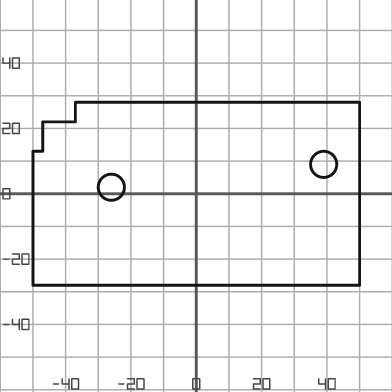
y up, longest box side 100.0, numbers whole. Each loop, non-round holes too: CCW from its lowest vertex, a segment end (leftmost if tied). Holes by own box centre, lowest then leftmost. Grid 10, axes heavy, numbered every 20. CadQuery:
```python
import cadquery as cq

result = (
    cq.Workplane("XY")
    .moveTo(-50.0, -28.0)
    .lineTo(50.0, -28.0)
    .lineTo(50.0, 28.0)
    .lineTo(-37.0, 28.0)
    .lineTo(-37.0, 22.0)
    .lineTo(-47.0, 22.0)
    .lineTo(-47.0, 13.0)
    .lineTo(-50.0, 13.0)
    .close()
    .moveTo(-26.0, 2.0)
    .circle(4.0)
    .moveTo(39.0, 9.0)
    .circle(4.0)
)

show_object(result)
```